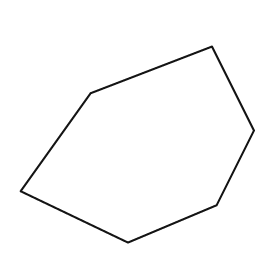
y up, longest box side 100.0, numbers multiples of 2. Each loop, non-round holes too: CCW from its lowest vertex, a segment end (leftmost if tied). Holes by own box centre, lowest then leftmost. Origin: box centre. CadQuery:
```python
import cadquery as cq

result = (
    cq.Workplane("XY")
    .moveTo(-4.0, -42.0)
    .lineTo(34.0, -26.0)
    .lineTo(50.0, 6.0)
    .lineTo(32.0, 42.0)
    .lineTo(-20.0, 22.0)
    .lineTo(-50.0, -20.0)
    .close()
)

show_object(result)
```